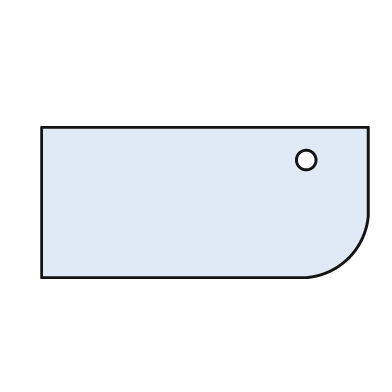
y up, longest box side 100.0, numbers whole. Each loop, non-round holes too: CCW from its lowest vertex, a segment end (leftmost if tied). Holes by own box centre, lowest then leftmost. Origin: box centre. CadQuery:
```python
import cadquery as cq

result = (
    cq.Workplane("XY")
    .moveTo(-50.0, -23.0)
    .lineTo(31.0, -23.0)
    .threePointArc((44.0, -17.0), (50.0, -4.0))
    .lineTo(50.0, 23.0)
    .lineTo(-50.0, 23.0)
    .close()
    .moveTo(31.0, 13.0)
    .circle(3.0)
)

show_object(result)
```